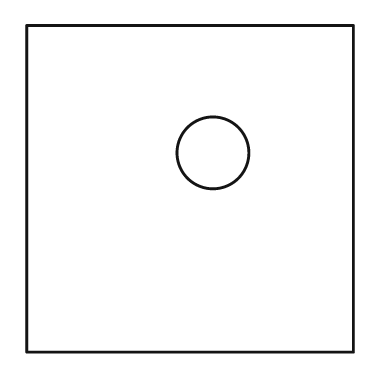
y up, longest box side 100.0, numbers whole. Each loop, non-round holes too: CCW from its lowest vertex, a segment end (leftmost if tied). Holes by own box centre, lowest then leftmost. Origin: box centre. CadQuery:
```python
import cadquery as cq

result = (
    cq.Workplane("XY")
    .moveTo(-50.0, -50.0)
    .lineTo(50.0, -50.0)
    .lineTo(50.0, 50.0)
    .lineTo(-50.0, 50.0)
    .close()
    .moveTo(7.0, 11.0)
    .circle(11.0)
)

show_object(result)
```